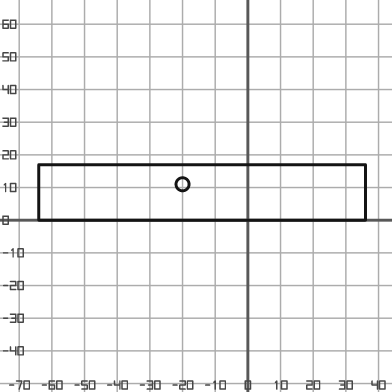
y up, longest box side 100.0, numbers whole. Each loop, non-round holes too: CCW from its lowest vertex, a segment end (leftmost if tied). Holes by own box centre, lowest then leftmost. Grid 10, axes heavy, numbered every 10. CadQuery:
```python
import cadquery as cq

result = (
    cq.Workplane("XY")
    .moveTo(-64.0, 0.0)
    .lineTo(36.0, 0.0)
    .lineTo(36.0, 17.0)
    .lineTo(-64.0, 17.0)
    .close()
    .moveTo(-20.0, 11.0)
    .circle(2.0)
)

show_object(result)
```